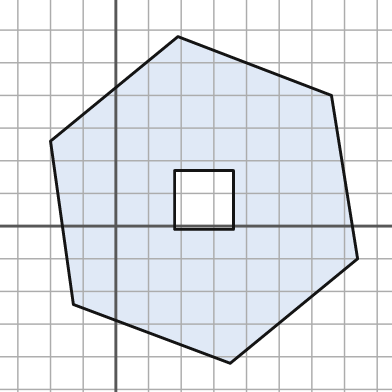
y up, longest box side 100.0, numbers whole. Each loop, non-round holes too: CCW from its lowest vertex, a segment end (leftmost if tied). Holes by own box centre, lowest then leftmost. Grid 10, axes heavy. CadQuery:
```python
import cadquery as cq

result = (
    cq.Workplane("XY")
    .moveTo(35.0, -42.0)
    .lineTo(74.0, -10.0)
    .lineTo(66.0, 40.0)
    .lineTo(19.0, 58.0)
    .lineTo(-20.0, 26.0)
    .lineTo(-13.0, -24.0)
    .close()
    .moveTo(18.0, -1.0)
    .lineTo(36.0, -1.0)
    .lineTo(36.0, 17.0)
    .lineTo(18.0, 17.0)
    .close()
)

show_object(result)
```